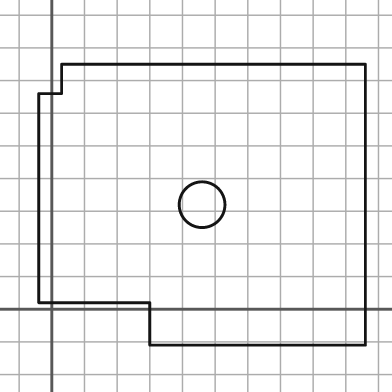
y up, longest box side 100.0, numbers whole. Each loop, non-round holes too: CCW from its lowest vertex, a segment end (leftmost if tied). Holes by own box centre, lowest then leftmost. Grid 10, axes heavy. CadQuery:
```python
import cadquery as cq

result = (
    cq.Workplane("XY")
    .moveTo(30.0, -11.0)
    .lineTo(96.0, -11.0)
    .lineTo(96.0, 75.0)
    .lineTo(3.0, 75.0)
    .lineTo(3.0, 66.0)
    .lineTo(-4.0, 66.0)
    .lineTo(-4.0, 2.0)
    .lineTo(30.0, 2.0)
    .close()
    .moveTo(46.0, 32.0)
    .circle(7.0)
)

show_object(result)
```